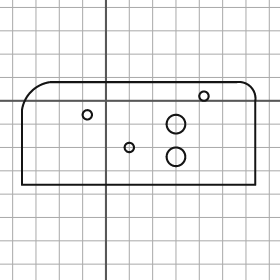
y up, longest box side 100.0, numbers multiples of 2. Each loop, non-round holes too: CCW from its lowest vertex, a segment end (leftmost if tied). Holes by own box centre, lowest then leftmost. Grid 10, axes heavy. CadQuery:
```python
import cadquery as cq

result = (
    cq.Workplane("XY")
    .moveTo(-36.0, -36.0)
    .lineTo(64.0, -36.0)
    .lineTo(64.0, 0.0)
    .threePointArc((62.0, 6.0), (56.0, 8.0))
    .lineTo(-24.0, 8.0)
    .threePointArc((-32.0, 4.0), (-36.0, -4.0))
    .close()
    .moveTo(30.0, -24.0)
    .circle(4.0)
    .moveTo(10.0, -20.0)
    .circle(2.0)
    .moveTo(30.0, -10.0)
    .circle(4.0)
    .moveTo(-8.0, -6.0)
    .circle(2.0)
    .moveTo(42.0, 2.0)
    .circle(2.0)
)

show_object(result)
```